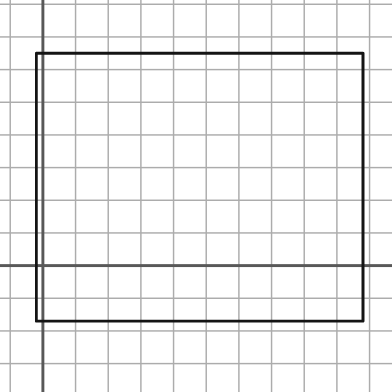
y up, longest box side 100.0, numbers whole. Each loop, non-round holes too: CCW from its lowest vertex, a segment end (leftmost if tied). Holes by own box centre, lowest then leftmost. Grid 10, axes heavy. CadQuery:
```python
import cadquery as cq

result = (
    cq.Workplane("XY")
    .moveTo(-2.0, -17.0)
    .lineTo(98.0, -17.0)
    .lineTo(98.0, 65.0)
    .lineTo(-2.0, 65.0)
    .close()
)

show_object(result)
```